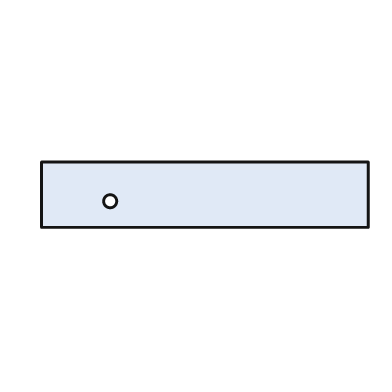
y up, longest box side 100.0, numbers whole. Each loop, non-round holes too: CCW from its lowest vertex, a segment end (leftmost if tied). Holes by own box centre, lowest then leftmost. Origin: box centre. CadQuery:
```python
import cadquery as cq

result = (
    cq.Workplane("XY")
    .moveTo(-50.0, -10.0)
    .lineTo(50.0, -10.0)
    .lineTo(50.0, 10.0)
    .lineTo(-50.0, 10.0)
    .close()
    .moveTo(-29.0, -2.0)
    .circle(2.0)
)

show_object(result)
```